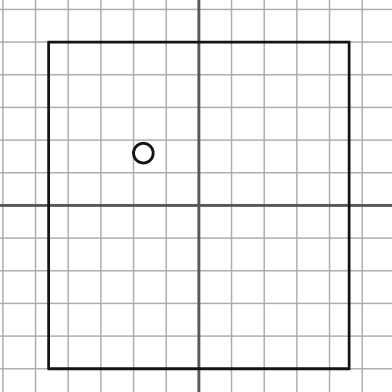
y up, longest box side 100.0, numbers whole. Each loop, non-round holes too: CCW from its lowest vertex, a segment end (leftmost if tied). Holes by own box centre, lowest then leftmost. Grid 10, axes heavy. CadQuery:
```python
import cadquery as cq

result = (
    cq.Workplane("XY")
    .moveTo(-46.0, -50.0)
    .lineTo(46.0, -50.0)
    .lineTo(46.0, 50.0)
    .lineTo(-46.0, 50.0)
    .close()
    .moveTo(-17.0, 16.0)
    .circle(3.0)
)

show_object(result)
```